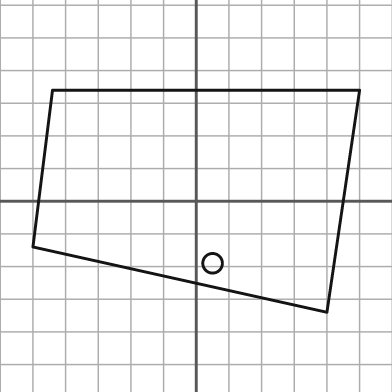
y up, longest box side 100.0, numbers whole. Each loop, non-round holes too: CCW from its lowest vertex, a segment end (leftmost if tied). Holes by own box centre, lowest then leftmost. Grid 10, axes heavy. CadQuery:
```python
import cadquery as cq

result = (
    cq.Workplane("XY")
    .moveTo(40.0, -34.0)
    .lineTo(50.0, 34.0)
    .lineTo(-44.0, 34.0)
    .lineTo(-50.0, -14.0)
    .close()
    .moveTo(5.0, -19.0)
    .circle(3.0)
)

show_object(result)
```